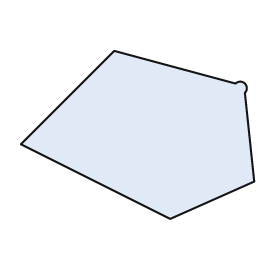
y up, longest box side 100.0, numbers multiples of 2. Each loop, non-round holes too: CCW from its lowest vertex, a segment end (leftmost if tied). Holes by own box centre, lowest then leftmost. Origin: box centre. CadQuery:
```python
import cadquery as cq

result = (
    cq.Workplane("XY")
    .moveTo(14.0, -36.0)
    .lineTo(50.0, -20.0)
    .lineTo(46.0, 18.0)
    .threePointArc((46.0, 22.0), (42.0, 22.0))
    .lineTo(-10.0, 36.0)
    .lineTo(-50.0, -4.0)
    .close()
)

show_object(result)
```